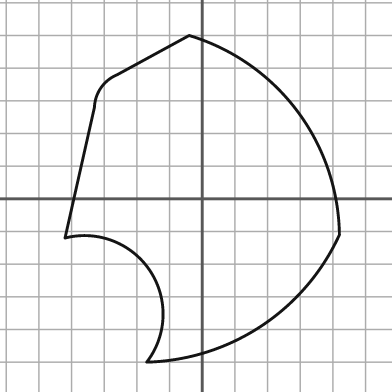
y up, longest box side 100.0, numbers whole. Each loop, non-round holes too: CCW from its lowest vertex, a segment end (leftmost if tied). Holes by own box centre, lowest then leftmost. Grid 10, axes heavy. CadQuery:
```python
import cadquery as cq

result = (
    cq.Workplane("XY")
    .moveTo(-17.0, -50.0)
    .threePointArc((18.0, -39.0), (42.0, -11.0))
    .threePointArc((29.0, 27.0), (-4.0, 50.0))
    .lineTo(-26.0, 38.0)
    .threePointArc((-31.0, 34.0), (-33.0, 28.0))
    .lineTo(-42.0, -12.0)
    .threePointArc((-16.0, -22.0), (-17.0, -50.0))
    .close()
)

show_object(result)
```